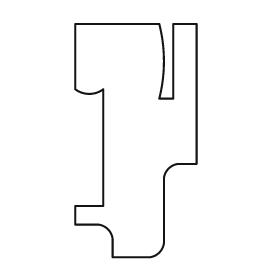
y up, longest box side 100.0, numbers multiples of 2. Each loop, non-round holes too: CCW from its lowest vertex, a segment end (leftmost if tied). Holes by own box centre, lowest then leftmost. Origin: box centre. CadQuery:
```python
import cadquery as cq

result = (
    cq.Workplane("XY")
    .moveTo(-10.0, -50.0)
    .lineTo(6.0, -50.0)
    .threePointArc((10.0, -48.0), (12.0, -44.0))
    .lineTo(12.0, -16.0)
    .threePointArc((14.0, -12.0), (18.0, -10.0))
    .lineTo(26.0, -10.0)
    .lineTo(26.0, 50.0)
    .lineTo(16.0, 50.0)
    .lineTo(16.0, 18.0)
    .lineTo(10.0, 18.0)
    .threePointArc((12.0, 34.0), (10.0, 50.0))
    .lineTo(-26.0, 50.0)
    .lineTo(-26.0, 22.0)
    .threePointArc((-20.0, 20.0), (-14.0, 22.0))
    .lineTo(-14.0, -28.0)
    .lineTo(-26.0, -28.0)
    .lineTo(-26.0, -36.0)
    .lineTo(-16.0, -36.0)
    .threePointArc((-12.0, -38.0), (-10.0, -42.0))
    .close()
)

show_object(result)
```